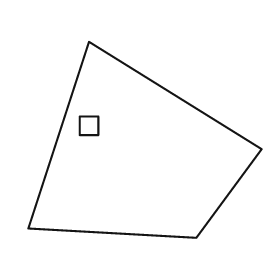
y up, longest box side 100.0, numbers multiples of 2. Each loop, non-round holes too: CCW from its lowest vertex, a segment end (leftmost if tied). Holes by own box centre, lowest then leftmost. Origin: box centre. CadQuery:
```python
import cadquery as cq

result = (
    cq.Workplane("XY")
    .moveTo(22.0, -42.0)
    .lineTo(50.0, -4.0)
    .lineTo(-24.0, 42.0)
    .lineTo(-50.0, -38.0)
    .close()
    .moveTo(-28.0, 2.0)
    .lineTo(-20.0, 2.0)
    .lineTo(-20.0, 10.0)
    .lineTo(-28.0, 10.0)
    .close()
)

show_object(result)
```